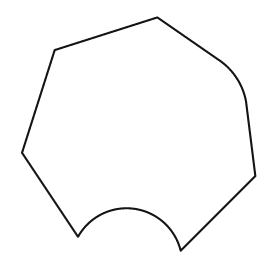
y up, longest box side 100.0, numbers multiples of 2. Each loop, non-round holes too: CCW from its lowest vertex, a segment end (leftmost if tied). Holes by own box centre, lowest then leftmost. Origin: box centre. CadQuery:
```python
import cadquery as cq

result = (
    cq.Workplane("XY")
    .moveTo(18.0, -50.0)
    .lineTo(50.0, -18.0)
    .lineTo(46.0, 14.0)
    .threePointArc((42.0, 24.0), (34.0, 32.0))
    .lineTo(8.0, 50.0)
    .lineTo(-36.0, 36.0)
    .lineTo(-50.0, -8.0)
    .lineTo(-26.0, -44.0)
    .threePointArc((-2.0, -32.0), (18.0, -50.0))
    .close()
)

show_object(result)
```